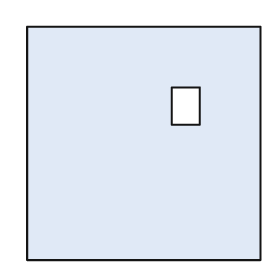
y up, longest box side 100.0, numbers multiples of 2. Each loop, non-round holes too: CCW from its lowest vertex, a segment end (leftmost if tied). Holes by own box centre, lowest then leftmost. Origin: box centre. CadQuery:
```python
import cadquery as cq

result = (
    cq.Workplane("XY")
    .moveTo(-50.0, -50.0)
    .lineTo(50.0, -50.0)
    .lineTo(50.0, 50.0)
    .lineTo(-50.0, 50.0)
    .close()
    .moveTo(12.0, 8.0)
    .lineTo(24.0, 8.0)
    .lineTo(24.0, 24.0)
    .lineTo(12.0, 24.0)
    .close()
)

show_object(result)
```